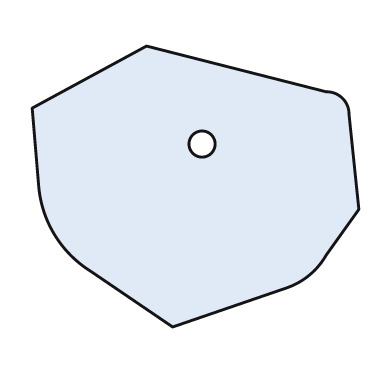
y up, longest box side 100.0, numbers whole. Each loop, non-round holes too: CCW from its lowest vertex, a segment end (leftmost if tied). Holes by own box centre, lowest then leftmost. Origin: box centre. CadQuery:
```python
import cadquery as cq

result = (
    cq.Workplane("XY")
    .moveTo(-7.0, -43.0)
    .lineTo(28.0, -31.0)
    .threePointArc((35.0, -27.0), (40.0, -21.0))
    .lineTo(50.0, -7.0)
    .lineTo(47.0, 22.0)
    .threePointArc((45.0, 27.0), (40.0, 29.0))
    .lineTo(-15.0, 43.0)
    .lineTo(-50.0, 24.0)
    .lineTo(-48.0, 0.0)
    .threePointArc((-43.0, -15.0), (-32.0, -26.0))
    .close()
    .moveTo(2.0, 13.0)
    .circle(4.0)
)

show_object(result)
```